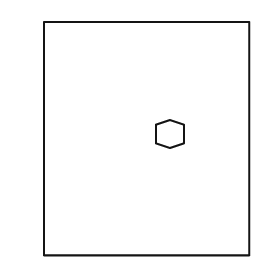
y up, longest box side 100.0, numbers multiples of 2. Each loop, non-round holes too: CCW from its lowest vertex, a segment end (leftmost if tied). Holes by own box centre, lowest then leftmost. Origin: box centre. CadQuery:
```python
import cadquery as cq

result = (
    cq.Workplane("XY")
    .moveTo(-44.0, -50.0)
    .lineTo(44.0, -50.0)
    .lineTo(44.0, 50.0)
    .lineTo(-44.0, 50.0)
    .close()
    .moveTo(10.0, -4.0)
    .lineTo(16.0, -2.0)
    .lineTo(16.0, 6.0)
    .lineTo(10.0, 8.0)
    .lineTo(4.0, 6.0)
    .lineTo(4.0, -2.0)
    .close()
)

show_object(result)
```